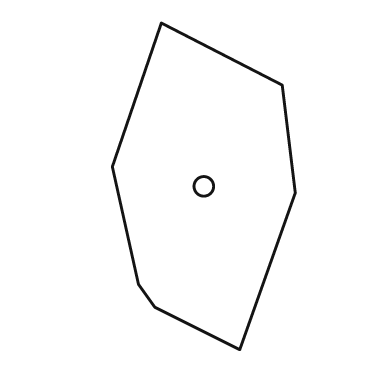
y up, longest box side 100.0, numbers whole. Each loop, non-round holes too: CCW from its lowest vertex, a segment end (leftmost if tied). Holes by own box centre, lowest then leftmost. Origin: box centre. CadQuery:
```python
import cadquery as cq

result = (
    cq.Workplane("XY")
    .moveTo(11.0, -50.0)
    .lineTo(28.0, -2.0)
    .lineTo(24.0, 31.0)
    .lineTo(-13.0, 50.0)
    .lineTo(-28.0, 6.0)
    .lineTo(-20.0, -30.0)
    .lineTo(-15.0, -37.0)
    .close()
    .moveTo(0.0, 0.0)
    .circle(3.0)
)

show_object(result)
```